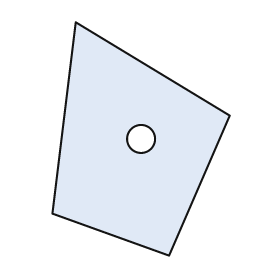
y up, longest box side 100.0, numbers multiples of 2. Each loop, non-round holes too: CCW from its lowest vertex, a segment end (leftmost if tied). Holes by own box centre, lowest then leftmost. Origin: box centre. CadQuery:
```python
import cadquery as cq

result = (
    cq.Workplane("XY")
    .moveTo(12.0, -50.0)
    .lineTo(38.0, 10.0)
    .lineTo(-28.0, 50.0)
    .lineTo(-38.0, -32.0)
    .close()
    .moveTo(0.0, 0.0)
    .circle(6.0)
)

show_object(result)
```